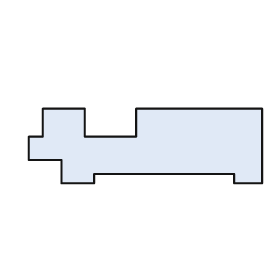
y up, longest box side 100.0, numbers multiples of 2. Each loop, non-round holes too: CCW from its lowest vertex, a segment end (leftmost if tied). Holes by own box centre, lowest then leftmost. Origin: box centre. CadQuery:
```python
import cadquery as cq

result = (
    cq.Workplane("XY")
    .moveTo(-36.0, -16.0)
    .lineTo(-22.0, -16.0)
    .lineTo(-22.0, -12.0)
    .lineTo(38.0, -12.0)
    .lineTo(38.0, -16.0)
    .lineTo(50.0, -16.0)
    .lineTo(50.0, 16.0)
    .lineTo(-4.0, 16.0)
    .lineTo(-4.0, 4.0)
    .lineTo(-26.0, 4.0)
    .lineTo(-26.0, 16.0)
    .lineTo(-44.0, 16.0)
    .lineTo(-44.0, 4.0)
    .lineTo(-50.0, 4.0)
    .lineTo(-50.0, -6.0)
    .lineTo(-36.0, -6.0)
    .close()
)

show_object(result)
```